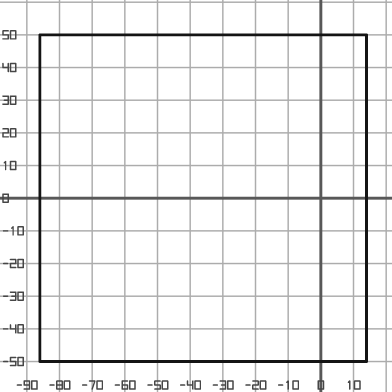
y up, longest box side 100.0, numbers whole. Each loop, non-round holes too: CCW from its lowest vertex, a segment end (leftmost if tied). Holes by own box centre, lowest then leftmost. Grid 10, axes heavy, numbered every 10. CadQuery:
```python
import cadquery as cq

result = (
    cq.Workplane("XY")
    .moveTo(-86.0, -50.0)
    .lineTo(14.0, -50.0)
    .lineTo(14.0, 50.0)
    .lineTo(-86.0, 50.0)
    .close()
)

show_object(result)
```